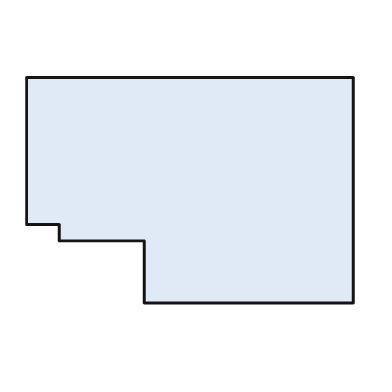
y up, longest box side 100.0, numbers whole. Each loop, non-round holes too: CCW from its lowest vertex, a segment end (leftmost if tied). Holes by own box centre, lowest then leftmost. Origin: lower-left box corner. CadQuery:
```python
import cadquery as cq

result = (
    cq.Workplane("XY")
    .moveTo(36.0, 0.0)
    .lineTo(100.0, 0.0)
    .lineTo(100.0, 69.0)
    .lineTo(0.0, 69.0)
    .lineTo(0.0, 24.0)
    .lineTo(10.0, 24.0)
    .lineTo(10.0, 19.0)
    .lineTo(36.0, 19.0)
    .close()
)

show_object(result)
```